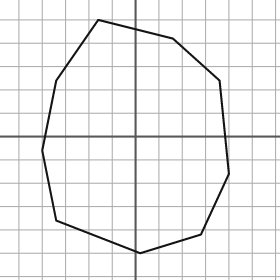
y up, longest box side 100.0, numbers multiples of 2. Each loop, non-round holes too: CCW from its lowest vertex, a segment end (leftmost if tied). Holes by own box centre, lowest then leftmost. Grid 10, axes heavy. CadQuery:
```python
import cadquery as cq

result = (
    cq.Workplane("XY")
    .moveTo(2.0, -50.0)
    .lineTo(28.0, -42.0)
    .lineTo(40.0, -16.0)
    .lineTo(36.0, 24.0)
    .lineTo(16.0, 42.0)
    .lineTo(-16.0, 50.0)
    .lineTo(-34.0, 24.0)
    .lineTo(-40.0, -6.0)
    .lineTo(-34.0, -36.0)
    .close()
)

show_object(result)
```